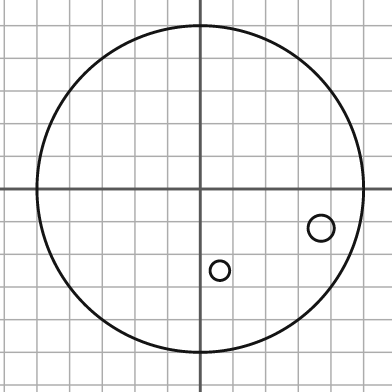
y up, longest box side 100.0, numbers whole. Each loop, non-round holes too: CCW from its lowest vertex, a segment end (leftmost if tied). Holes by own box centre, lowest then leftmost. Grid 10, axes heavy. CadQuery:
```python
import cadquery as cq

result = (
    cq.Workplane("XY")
    .moveTo(0.0, 0.0)
    .circle(50.0)
    .moveTo(6.0, -25.0)
    .circle(3.0)
    .moveTo(37.0, -12.0)
    .circle(4.0)
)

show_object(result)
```